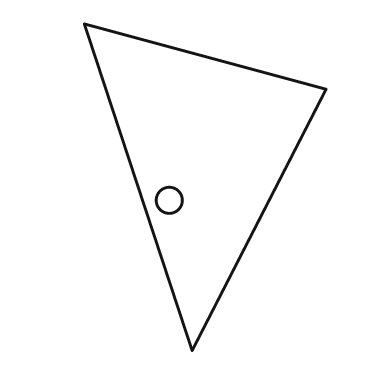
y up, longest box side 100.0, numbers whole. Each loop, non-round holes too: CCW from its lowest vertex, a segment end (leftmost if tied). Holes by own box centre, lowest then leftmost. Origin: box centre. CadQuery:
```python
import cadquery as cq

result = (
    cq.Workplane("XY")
    .moveTo(-4.0, -50.0)
    .lineTo(37.0, 30.0)
    .lineTo(-37.0, 50.0)
    .close()
    .moveTo(-11.0, -4.0)
    .circle(4.0)
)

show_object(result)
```